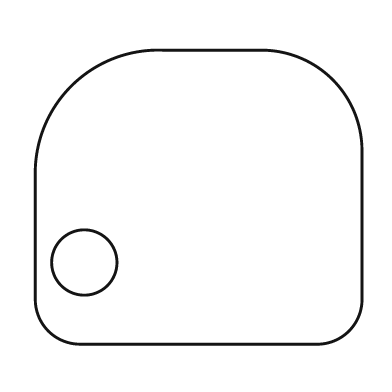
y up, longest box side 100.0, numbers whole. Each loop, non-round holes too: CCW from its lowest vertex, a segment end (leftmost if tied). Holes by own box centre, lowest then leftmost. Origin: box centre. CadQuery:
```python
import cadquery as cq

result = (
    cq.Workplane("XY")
    .moveTo(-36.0, -45.0)
    .lineTo(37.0, -45.0)
    .threePointArc((46.0, -41.0), (50.0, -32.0))
    .lineTo(50.0, 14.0)
    .threePointArc((41.0, 36.0), (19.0, 45.0))
    .lineTo(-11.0, 45.0)
    .threePointArc((-39.0, 34.0), (-50.0, 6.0))
    .lineTo(-50.0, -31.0)
    .threePointArc((-46.0, -41.0), (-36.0, -45.0))
    .close()
    .moveTo(-35.0, -20.0)
    .circle(10.0)
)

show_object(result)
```